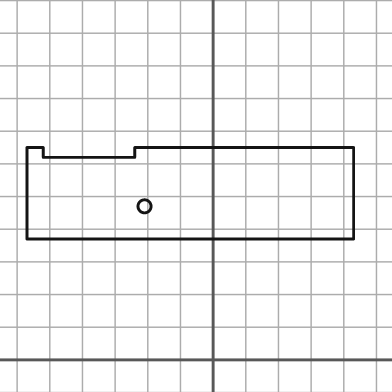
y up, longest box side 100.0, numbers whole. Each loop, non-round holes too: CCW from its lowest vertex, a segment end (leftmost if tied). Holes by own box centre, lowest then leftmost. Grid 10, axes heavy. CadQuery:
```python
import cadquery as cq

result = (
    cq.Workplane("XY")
    .moveTo(-57.0, 37.0)
    .lineTo(43.0, 37.0)
    .lineTo(43.0, 65.0)
    .lineTo(-24.0, 65.0)
    .lineTo(-24.0, 62.0)
    .lineTo(-52.0, 62.0)
    .lineTo(-52.0, 65.0)
    .lineTo(-57.0, 65.0)
    .close()
    .moveTo(-21.0, 47.0)
    .circle(2.0)
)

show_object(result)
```